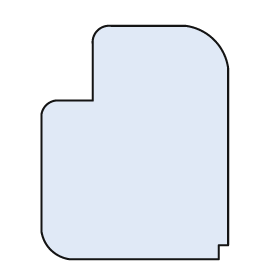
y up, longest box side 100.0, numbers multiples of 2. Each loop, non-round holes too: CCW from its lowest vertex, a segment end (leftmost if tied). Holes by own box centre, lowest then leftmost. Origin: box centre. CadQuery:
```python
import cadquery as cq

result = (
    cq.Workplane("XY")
    .moveTo(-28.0, -50.0)
    .lineTo(36.0, -50.0)
    .lineTo(36.0, -44.0)
    .lineTo(40.0, -44.0)
    .lineTo(40.0, 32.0)
    .threePointArc((34.0, 44.0), (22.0, 50.0))
    .lineTo(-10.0, 50.0)
    .threePointArc((-16.0, 48.0), (-18.0, 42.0))
    .lineTo(-18.0, 18.0)
    .lineTo(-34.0, 18.0)
    .threePointArc((-38.0, 16.0), (-40.0, 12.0))
    .lineTo(-40.0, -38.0)
    .threePointArc((-36.0, -46.0), (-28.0, -50.0))
    .close()
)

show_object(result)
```